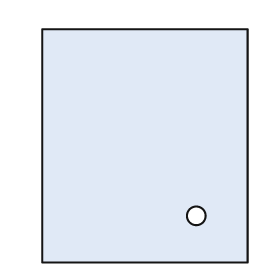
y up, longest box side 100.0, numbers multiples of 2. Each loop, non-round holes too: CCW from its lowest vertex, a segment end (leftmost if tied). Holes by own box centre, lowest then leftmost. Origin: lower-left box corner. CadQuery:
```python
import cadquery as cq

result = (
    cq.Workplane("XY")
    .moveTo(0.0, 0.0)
    .lineTo(88.0, 0.0)
    .lineTo(88.0, 100.0)
    .lineTo(0.0, 100.0)
    .close()
    .moveTo(66.0, 20.0)
    .circle(4.0)
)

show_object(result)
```